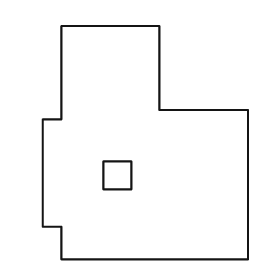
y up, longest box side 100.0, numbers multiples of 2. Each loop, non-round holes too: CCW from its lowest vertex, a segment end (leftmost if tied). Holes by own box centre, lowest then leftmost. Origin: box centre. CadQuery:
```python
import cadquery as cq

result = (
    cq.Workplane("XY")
    .moveTo(-36.0, -50.0)
    .lineTo(44.0, -50.0)
    .lineTo(44.0, 14.0)
    .lineTo(6.0, 14.0)
    .lineTo(6.0, 50.0)
    .lineTo(-36.0, 50.0)
    .lineTo(-36.0, 10.0)
    .lineTo(-44.0, 10.0)
    .lineTo(-44.0, -36.0)
    .lineTo(-36.0, -36.0)
    .close()
    .moveTo(-18.0, -20.0)
    .lineTo(-6.0, -20.0)
    .lineTo(-6.0, -8.0)
    .lineTo(-18.0, -8.0)
    .close()
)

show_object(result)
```